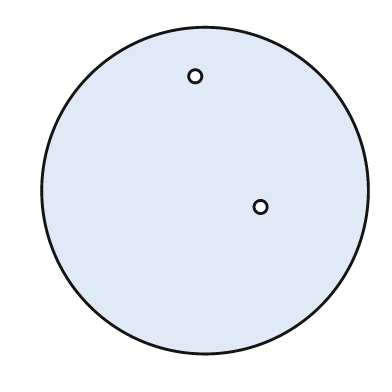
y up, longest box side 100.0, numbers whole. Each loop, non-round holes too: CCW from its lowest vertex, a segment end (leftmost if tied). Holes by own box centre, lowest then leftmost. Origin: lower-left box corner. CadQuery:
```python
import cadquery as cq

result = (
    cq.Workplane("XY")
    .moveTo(50.0, 50.0)
    .circle(50.0)
    .moveTo(67.0, 45.0)
    .circle(2.0)
    .moveTo(47.0, 85.0)
    .circle(2.0)
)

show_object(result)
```